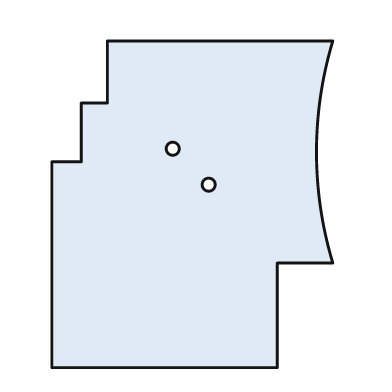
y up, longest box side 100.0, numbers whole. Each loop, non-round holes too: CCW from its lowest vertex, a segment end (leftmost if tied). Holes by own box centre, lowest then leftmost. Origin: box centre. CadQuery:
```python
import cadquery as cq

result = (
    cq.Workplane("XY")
    .moveTo(-43.0, -50.0)
    .lineTo(26.0, -50.0)
    .lineTo(26.0, -18.0)
    .lineTo(43.0, -18.0)
    .threePointArc((38.0, 16.0), (43.0, 50.0))
    .lineTo(-26.0, 50.0)
    .lineTo(-26.0, 31.0)
    .lineTo(-34.0, 31.0)
    .lineTo(-34.0, 13.0)
    .lineTo(-43.0, 13.0)
    .close()
    .moveTo(5.0, 6.0)
    .circle(2.0)
    .moveTo(-6.0, 17.0)
    .circle(2.0)
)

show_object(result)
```